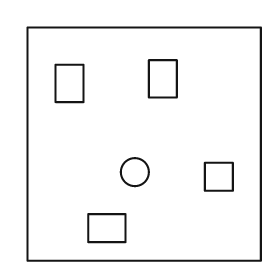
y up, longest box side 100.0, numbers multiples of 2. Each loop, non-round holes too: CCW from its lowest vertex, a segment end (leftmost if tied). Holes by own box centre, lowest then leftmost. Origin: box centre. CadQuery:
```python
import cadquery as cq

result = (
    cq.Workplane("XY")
    .moveTo(-50.0, -50.0)
    .lineTo(50.0, -50.0)
    .lineTo(50.0, 50.0)
    .lineTo(-50.0, 50.0)
    .close()
    .moveTo(-24.0, -42.0)
    .lineTo(-8.0, -42.0)
    .lineTo(-8.0, -30.0)
    .lineTo(-24.0, -30.0)
    .close()
    .moveTo(26.0, -20.0)
    .lineTo(38.0, -20.0)
    .lineTo(38.0, -8.0)
    .lineTo(26.0, -8.0)
    .close()
    .moveTo(-4.0, -12.0)
    .circle(6.0)
    .moveTo(-38.0, 18.0)
    .lineTo(-26.0, 18.0)
    .lineTo(-26.0, 34.0)
    .lineTo(-38.0, 34.0)
    .close()
    .moveTo(2.0, 20.0)
    .lineTo(14.0, 20.0)
    .lineTo(14.0, 36.0)
    .lineTo(2.0, 36.0)
    .close()
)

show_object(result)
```